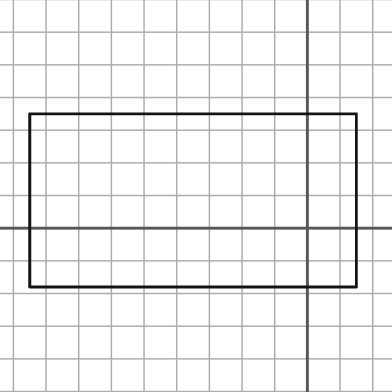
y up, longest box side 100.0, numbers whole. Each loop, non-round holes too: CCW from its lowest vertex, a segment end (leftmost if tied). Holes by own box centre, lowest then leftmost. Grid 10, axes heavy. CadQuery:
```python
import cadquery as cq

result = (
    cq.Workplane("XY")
    .moveTo(-85.0, -18.0)
    .lineTo(15.0, -18.0)
    .lineTo(15.0, 35.0)
    .lineTo(-85.0, 35.0)
    .close()
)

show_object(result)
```